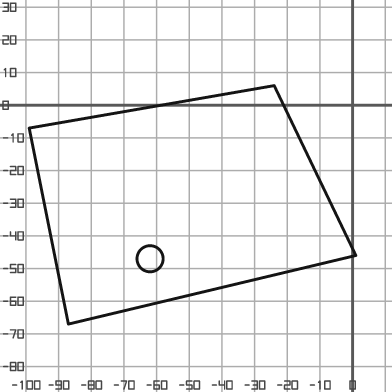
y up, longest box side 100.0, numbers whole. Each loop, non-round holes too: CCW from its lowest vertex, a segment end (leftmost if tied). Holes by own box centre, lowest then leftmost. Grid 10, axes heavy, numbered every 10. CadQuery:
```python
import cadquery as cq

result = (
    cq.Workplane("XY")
    .moveTo(-87.0, -67.0)
    .lineTo(1.0, -46.0)
    .lineTo(-24.0, 6.0)
    .lineTo(-99.0, -7.0)
    .close()
    .moveTo(-62.0, -47.0)
    .circle(4.0)
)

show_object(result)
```